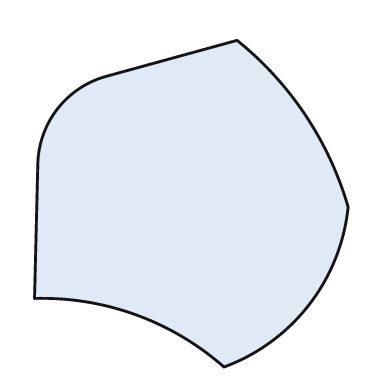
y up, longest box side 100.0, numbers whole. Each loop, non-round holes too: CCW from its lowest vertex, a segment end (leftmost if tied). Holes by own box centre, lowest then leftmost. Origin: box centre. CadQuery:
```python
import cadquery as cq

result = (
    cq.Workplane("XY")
    .moveTo(10.0, -50.0)
    .threePointArc((36.0, -31.0), (48.0, -1.0))
    .threePointArc((35.0, 27.0), (14.0, 50.0))
    .lineTo(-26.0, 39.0)
    .threePointArc((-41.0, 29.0), (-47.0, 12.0))
    .lineTo(-48.0, -29.0)
    .threePointArc((-17.0, -34.0), (10.0, -50.0))
    .close()
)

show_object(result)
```